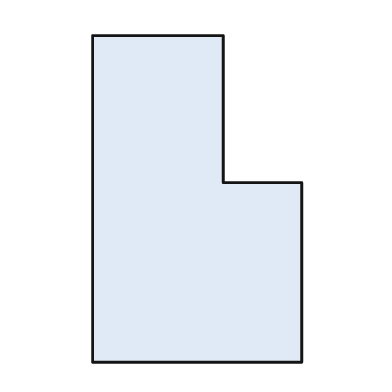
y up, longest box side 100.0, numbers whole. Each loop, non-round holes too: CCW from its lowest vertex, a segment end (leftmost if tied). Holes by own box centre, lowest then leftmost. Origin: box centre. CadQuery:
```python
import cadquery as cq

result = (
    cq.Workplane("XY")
    .moveTo(-32.0, -50.0)
    .lineTo(32.0, -50.0)
    .lineTo(32.0, 5.0)
    .lineTo(8.0, 5.0)
    .lineTo(8.0, 50.0)
    .lineTo(-32.0, 50.0)
    .close()
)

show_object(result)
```